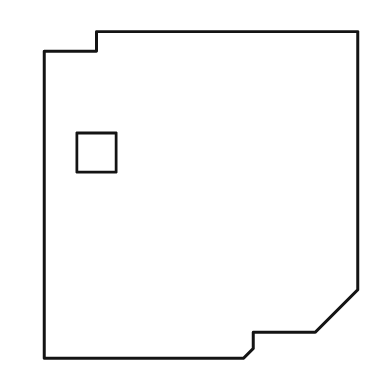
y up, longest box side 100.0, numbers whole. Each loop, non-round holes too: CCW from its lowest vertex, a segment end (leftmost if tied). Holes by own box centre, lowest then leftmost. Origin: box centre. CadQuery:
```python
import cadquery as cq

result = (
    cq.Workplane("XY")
    .moveTo(-48.0, -50.0)
    .lineTo(13.0, -50.0)
    .lineTo(16.0, -47.0)
    .lineTo(16.0, -42.0)
    .lineTo(35.0, -42.0)
    .lineTo(48.0, -29.0)
    .lineTo(48.0, 50.0)
    .lineTo(-32.0, 50.0)
    .lineTo(-32.0, 44.0)
    .lineTo(-48.0, 44.0)
    .close()
    .moveTo(-38.0, 7.0)
    .lineTo(-26.0, 7.0)
    .lineTo(-26.0, 19.0)
    .lineTo(-38.0, 19.0)
    .close()
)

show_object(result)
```